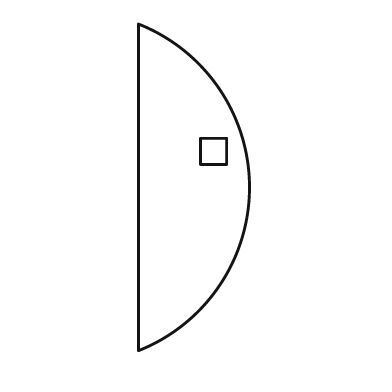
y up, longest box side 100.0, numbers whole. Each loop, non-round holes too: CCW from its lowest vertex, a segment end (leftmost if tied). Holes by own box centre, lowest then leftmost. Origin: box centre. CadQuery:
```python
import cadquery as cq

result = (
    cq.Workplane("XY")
    .moveTo(-17.0, -50.0)
    .threePointArc((17.0, 0.0), (-17.0, 50.0))
    .close()
    .moveTo(2.0, 7.0)
    .lineTo(10.0, 7.0)
    .lineTo(10.0, 15.0)
    .lineTo(2.0, 15.0)
    .close()
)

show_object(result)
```